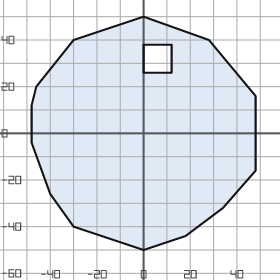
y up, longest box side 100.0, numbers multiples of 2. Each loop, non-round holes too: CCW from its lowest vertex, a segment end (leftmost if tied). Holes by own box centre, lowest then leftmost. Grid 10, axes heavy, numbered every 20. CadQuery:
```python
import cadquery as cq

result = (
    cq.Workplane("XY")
    .moveTo(0.0, -50.0)
    .lineTo(18.0, -44.0)
    .lineTo(34.0, -32.0)
    .lineTo(48.0, -16.0)
    .lineTo(48.0, 16.0)
    .lineTo(28.0, 40.0)
    .lineTo(0.0, 50.0)
    .lineTo(-30.0, 40.0)
    .lineTo(-46.0, 20.0)
    .lineTo(-48.0, 12.0)
    .lineTo(-48.0, -4.0)
    .lineTo(-40.0, -26.0)
    .lineTo(-30.0, -40.0)
    .close()
    .moveTo(0.0, 26.0)
    .lineTo(12.0, 26.0)
    .lineTo(12.0, 38.0)
    .lineTo(0.0, 38.0)
    .close()
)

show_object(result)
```